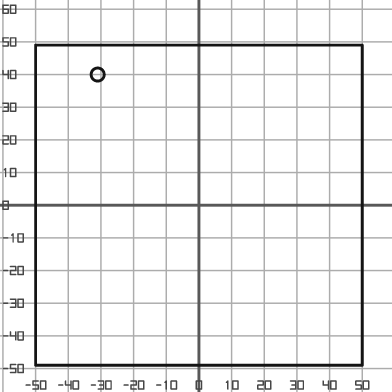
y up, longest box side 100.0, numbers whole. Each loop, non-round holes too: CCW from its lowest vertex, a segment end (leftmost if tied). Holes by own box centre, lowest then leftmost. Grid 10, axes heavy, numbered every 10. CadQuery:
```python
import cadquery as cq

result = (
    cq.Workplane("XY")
    .moveTo(-50.0, -49.0)
    .lineTo(50.0, -49.0)
    .lineTo(50.0, 49.0)
    .lineTo(-50.0, 49.0)
    .close()
    .moveTo(-31.0, 40.0)
    .circle(2.0)
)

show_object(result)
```